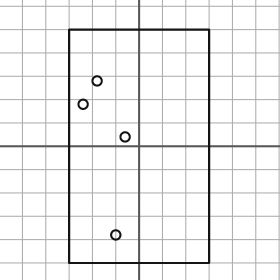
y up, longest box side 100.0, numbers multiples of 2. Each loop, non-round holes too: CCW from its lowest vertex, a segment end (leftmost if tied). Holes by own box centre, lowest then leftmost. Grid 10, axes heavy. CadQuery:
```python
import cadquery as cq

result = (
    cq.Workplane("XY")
    .moveTo(-30.0, -50.0)
    .lineTo(30.0, -50.0)
    .lineTo(30.0, 50.0)
    .lineTo(-30.0, 50.0)
    .close()
    .moveTo(-10.0, -38.0)
    .circle(2.0)
    .moveTo(-6.0, 4.0)
    .circle(2.0)
    .moveTo(-24.0, 18.0)
    .circle(2.0)
    .moveTo(-18.0, 28.0)
    .circle(2.0)
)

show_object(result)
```